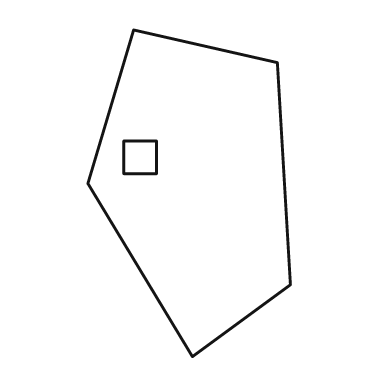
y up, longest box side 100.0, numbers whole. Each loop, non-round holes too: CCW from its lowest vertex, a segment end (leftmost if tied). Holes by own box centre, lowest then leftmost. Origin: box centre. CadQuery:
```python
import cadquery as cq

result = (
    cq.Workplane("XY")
    .moveTo(1.0, -50.0)
    .lineTo(31.0, -28.0)
    .lineTo(27.0, 40.0)
    .lineTo(-17.0, 50.0)
    .lineTo(-31.0, 3.0)
    .close()
    .moveTo(-20.0, 6.0)
    .lineTo(-10.0, 6.0)
    .lineTo(-10.0, 16.0)
    .lineTo(-20.0, 16.0)
    .close()
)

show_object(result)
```